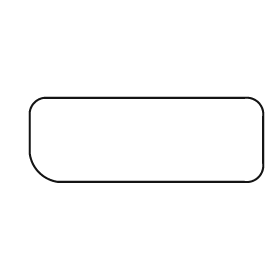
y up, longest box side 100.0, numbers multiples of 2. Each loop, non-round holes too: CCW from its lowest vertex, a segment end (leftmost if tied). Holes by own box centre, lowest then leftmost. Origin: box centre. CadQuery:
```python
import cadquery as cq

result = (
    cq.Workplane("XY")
    .moveTo(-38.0, -18.0)
    .lineTo(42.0, -18.0)
    .threePointArc((48.0, -16.0), (50.0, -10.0))
    .lineTo(50.0, 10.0)
    .threePointArc((48.0, 16.0), (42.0, 18.0))
    .lineTo(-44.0, 18.0)
    .threePointArc((-48.0, 16.0), (-50.0, 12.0))
    .lineTo(-50.0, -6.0)
    .threePointArc((-46.0, -14.0), (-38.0, -18.0))
    .close()
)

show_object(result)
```